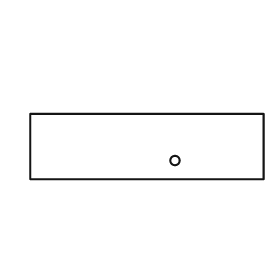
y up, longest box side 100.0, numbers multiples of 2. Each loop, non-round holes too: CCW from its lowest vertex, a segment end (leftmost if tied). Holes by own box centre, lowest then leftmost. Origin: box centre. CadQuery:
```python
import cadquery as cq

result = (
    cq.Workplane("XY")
    .moveTo(-50.0, -14.0)
    .lineTo(50.0, -14.0)
    .lineTo(50.0, 14.0)
    .lineTo(-50.0, 14.0)
    .close()
    .moveTo(12.0, -6.0)
    .circle(2.0)
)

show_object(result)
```